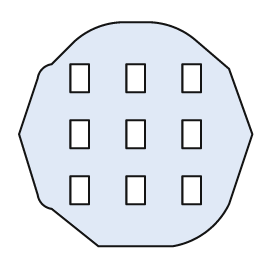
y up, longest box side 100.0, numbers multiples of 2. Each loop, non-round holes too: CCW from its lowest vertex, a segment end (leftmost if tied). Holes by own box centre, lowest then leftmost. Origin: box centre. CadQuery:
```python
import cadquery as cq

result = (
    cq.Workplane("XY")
    .moveTo(-16.0, -48.0)
    .lineTo(16.0, -48.0)
    .threePointArc((30.0, -42.0), (40.0, -30.0))
    .lineTo(50.0, 0.0)
    .lineTo(40.0, 28.0)
    .lineTo(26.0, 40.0)
    .threePointArc((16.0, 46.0), (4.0, 48.0))
    .lineTo(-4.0, 48.0)
    .threePointArc((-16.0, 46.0), (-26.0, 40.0))
    .lineTo(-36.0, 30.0)
    .threePointArc((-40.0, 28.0), (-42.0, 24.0))
    .lineTo(-50.0, 0.0)
    .lineTo(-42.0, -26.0)
    .threePointArc((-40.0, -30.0), (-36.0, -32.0))
    .close()
    .moveTo(-28.0, -30.0)
    .lineTo(-20.0, -30.0)
    .lineTo(-20.0, -18.0)
    .lineTo(-28.0, -18.0)
    .close()
    .moveTo(-4.0, -30.0)
    .lineTo(4.0, -30.0)
    .lineTo(4.0, -18.0)
    .lineTo(-4.0, -18.0)
    .close()
    .moveTo(20.0, -30.0)
    .lineTo(28.0, -30.0)
    .lineTo(28.0, -18.0)
    .lineTo(20.0, -18.0)
    .close()
    .moveTo(-28.0, -6.0)
    .lineTo(-20.0, -6.0)
    .lineTo(-20.0, 6.0)
    .lineTo(-28.0, 6.0)
    .close()
    .moveTo(-4.0, -6.0)
    .lineTo(4.0, -6.0)
    .lineTo(4.0, 6.0)
    .lineTo(-4.0, 6.0)
    .close()
    .moveTo(20.0, -6.0)
    .lineTo(28.0, -6.0)
    .lineTo(28.0, 6.0)
    .lineTo(20.0, 6.0)
    .close()
    .moveTo(-28.0, 18.0)
    .lineTo(-20.0, 18.0)
    .lineTo(-20.0, 30.0)
    .lineTo(-28.0, 30.0)
    .close()
    .moveTo(-4.0, 18.0)
    .lineTo(4.0, 18.0)
    .lineTo(4.0, 30.0)
    .lineTo(-4.0, 30.0)
    .close()
    .moveTo(20.0, 18.0)
    .lineTo(28.0, 18.0)
    .lineTo(28.0, 30.0)
    .lineTo(20.0, 30.0)
    .close()
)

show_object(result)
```